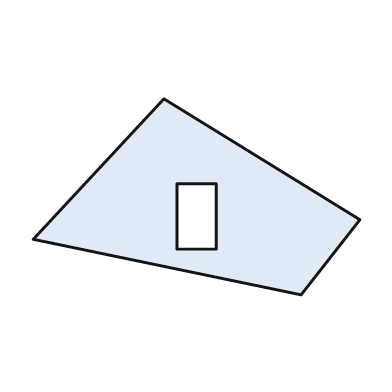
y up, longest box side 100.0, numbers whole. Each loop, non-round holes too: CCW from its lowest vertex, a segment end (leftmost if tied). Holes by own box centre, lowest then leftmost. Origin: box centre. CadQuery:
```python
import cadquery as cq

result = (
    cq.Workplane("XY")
    .moveTo(32.0, -30.0)
    .lineTo(50.0, -7.0)
    .lineTo(-10.0, 30.0)
    .lineTo(-50.0, -13.0)
    .close()
    .moveTo(-6.0, -16.0)
    .lineTo(6.0, -16.0)
    .lineTo(6.0, 4.0)
    .lineTo(-6.0, 4.0)
    .close()
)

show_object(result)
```